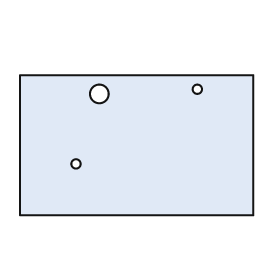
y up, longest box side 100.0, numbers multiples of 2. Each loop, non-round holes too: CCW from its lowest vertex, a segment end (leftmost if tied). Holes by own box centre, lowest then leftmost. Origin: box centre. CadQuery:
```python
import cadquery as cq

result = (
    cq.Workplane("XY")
    .moveTo(-50.0, -30.0)
    .lineTo(50.0, -30.0)
    .lineTo(50.0, 30.0)
    .lineTo(-50.0, 30.0)
    .close()
    .moveTo(-26.0, -8.0)
    .circle(2.0)
    .moveTo(-16.0, 22.0)
    .circle(4.0)
    .moveTo(26.0, 24.0)
    .circle(2.0)
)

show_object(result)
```